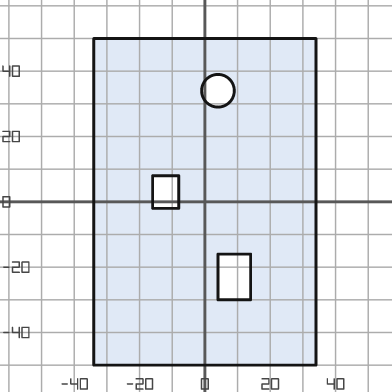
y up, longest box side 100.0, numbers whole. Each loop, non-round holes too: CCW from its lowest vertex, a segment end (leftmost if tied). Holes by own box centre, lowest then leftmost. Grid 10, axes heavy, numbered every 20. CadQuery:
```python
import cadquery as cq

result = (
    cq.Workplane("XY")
    .moveTo(-34.0, -50.0)
    .lineTo(34.0, -50.0)
    .lineTo(34.0, 50.0)
    .lineTo(-34.0, 50.0)
    .close()
    .moveTo(4.0, -30.0)
    .lineTo(14.0, -30.0)
    .lineTo(14.0, -16.0)
    .lineTo(4.0, -16.0)
    .close()
    .moveTo(-16.0, -2.0)
    .lineTo(-8.0, -2.0)
    .lineTo(-8.0, 8.0)
    .lineTo(-16.0, 8.0)
    .close()
    .moveTo(4.0, 34.0)
    .circle(5.0)
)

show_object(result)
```